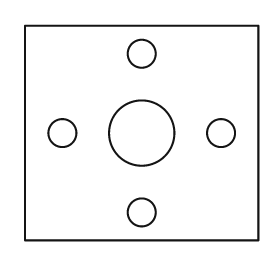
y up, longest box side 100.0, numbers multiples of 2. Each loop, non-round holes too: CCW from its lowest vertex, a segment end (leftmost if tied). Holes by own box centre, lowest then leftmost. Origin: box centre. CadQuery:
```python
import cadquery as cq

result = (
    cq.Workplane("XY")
    .moveTo(-50.0, -46.0)
    .lineTo(50.0, -46.0)
    .lineTo(50.0, 46.0)
    .lineTo(-50.0, 46.0)
    .close()
    .moveTo(0.0, -34.0)
    .circle(6.0)
    .moveTo(-34.0, 0.0)
    .circle(6.0)
    .moveTo(0.0, 0.0)
    .circle(14.0)
    .moveTo(34.0, 0.0)
    .circle(6.0)
    .moveTo(0.0, 34.0)
    .circle(6.0)
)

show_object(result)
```